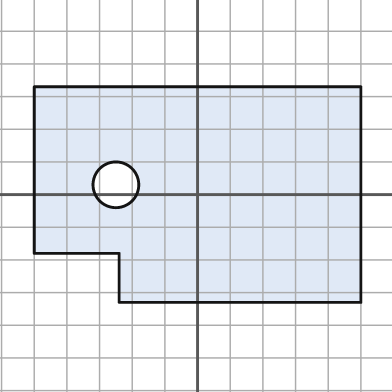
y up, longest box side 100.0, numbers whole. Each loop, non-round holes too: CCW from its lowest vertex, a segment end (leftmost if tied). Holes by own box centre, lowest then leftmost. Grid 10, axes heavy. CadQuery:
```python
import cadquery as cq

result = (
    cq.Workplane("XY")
    .moveTo(-24.0, -33.0)
    .lineTo(50.0, -33.0)
    .lineTo(50.0, 33.0)
    .lineTo(-50.0, 33.0)
    .lineTo(-50.0, -18.0)
    .lineTo(-24.0, -18.0)
    .close()
    .moveTo(-25.0, 3.0)
    .circle(7.0)
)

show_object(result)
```